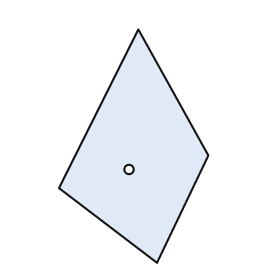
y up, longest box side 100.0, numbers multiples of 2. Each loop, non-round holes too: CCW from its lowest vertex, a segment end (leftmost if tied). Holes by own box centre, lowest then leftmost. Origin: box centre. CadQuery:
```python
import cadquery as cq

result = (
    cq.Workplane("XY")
    .moveTo(10.0, -50.0)
    .lineTo(32.0, -4.0)
    .lineTo(2.0, 50.0)
    .lineTo(-32.0, -18.0)
    .close()
    .moveTo(-2.0, -10.0)
    .circle(2.0)
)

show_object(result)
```